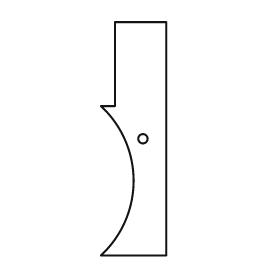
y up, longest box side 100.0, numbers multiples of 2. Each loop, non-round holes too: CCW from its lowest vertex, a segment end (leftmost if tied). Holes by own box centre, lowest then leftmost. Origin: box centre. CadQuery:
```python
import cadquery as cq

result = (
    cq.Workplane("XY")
    .moveTo(-14.0, -50.0)
    .lineTo(14.0, -50.0)
    .lineTo(14.0, 50.0)
    .lineTo(-8.0, 50.0)
    .lineTo(-8.0, 14.0)
    .lineTo(-14.0, 14.0)
    .threePointArc((0.0, -18.0), (-14.0, -50.0))
    .close()
    .moveTo(4.0, 0.0)
    .circle(2.0)
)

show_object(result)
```